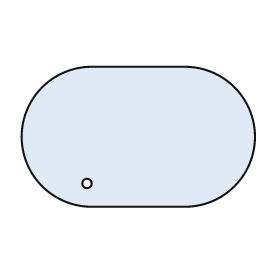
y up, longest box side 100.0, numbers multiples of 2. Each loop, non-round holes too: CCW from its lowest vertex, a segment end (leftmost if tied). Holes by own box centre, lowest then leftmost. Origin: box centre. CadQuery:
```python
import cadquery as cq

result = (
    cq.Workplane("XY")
    .moveTo(-20.0, -30.0)
    .lineTo(20.0, -30.0)
    .threePointArc((50.0, 0.0), (20.0, 30.0))
    .lineTo(-20.0, 30.0)
    .threePointArc((-50.0, 0.0), (-20.0, -30.0))
    .close()
    .moveTo(-22.0, -20.0)
    .circle(2.0)
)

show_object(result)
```